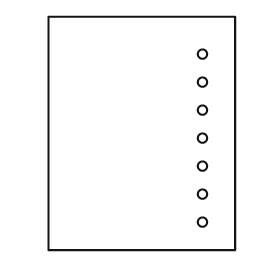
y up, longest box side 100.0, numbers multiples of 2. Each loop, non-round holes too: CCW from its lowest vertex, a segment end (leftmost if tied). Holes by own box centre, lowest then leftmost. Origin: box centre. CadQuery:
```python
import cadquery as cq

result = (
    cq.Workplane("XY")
    .moveTo(-40.0, -50.0)
    .lineTo(40.0, -50.0)
    .lineTo(40.0, 50.0)
    .lineTo(-40.0, 50.0)
    .close()
    .moveTo(26.0, -38.0)
    .circle(2.0)
    .moveTo(26.0, -26.0)
    .circle(2.0)
    .moveTo(26.0, -14.0)
    .circle(2.0)
    .moveTo(26.0, -2.0)
    .circle(2.0)
    .moveTo(26.0, 10.0)
    .circle(2.0)
    .moveTo(26.0, 22.0)
    .circle(2.0)
    .moveTo(26.0, 34.0)
    .circle(2.0)
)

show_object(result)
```